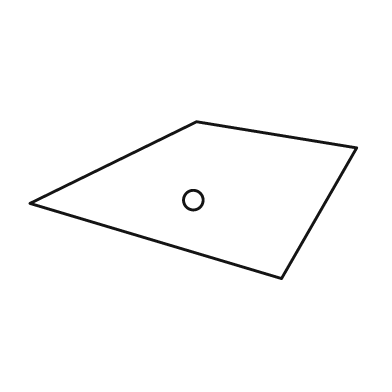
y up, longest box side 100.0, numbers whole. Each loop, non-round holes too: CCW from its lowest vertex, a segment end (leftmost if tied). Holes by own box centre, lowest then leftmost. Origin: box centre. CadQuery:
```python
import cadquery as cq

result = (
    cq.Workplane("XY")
    .moveTo(27.0, -24.0)
    .lineTo(50.0, 16.0)
    .lineTo(1.0, 24.0)
    .lineTo(-50.0, -1.0)
    .close()
    .moveTo(0.0, 0.0)
    .circle(3.0)
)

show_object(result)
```